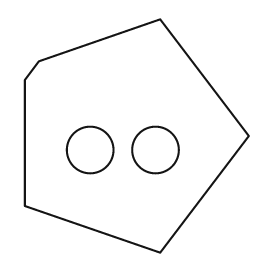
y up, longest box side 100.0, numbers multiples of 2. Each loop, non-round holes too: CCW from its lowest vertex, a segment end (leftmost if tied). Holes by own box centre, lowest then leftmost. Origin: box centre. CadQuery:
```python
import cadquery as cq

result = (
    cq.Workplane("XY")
    .moveTo(10.0, -50.0)
    .lineTo(48.0, 0.0)
    .lineTo(10.0, 50.0)
    .lineTo(-42.0, 32.0)
    .lineTo(-48.0, 24.0)
    .lineTo(-48.0, -30.0)
    .close()
    .moveTo(-20.0, -6.0)
    .circle(10.0)
    .moveTo(8.0, -6.0)
    .circle(10.0)
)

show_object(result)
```